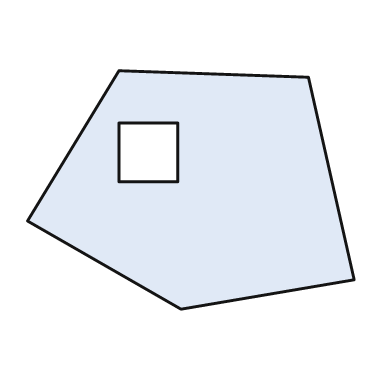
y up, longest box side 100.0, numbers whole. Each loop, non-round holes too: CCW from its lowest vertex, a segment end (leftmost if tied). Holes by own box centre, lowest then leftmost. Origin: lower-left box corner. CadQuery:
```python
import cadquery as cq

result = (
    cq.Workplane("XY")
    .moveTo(47.0, 0.0)
    .lineTo(100.0, 9.0)
    .lineTo(86.0, 71.0)
    .lineTo(28.0, 73.0)
    .lineTo(0.0, 27.0)
    .close()
    .moveTo(28.0, 39.0)
    .lineTo(46.0, 39.0)
    .lineTo(46.0, 57.0)
    .lineTo(28.0, 57.0)
    .close()
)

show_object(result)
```